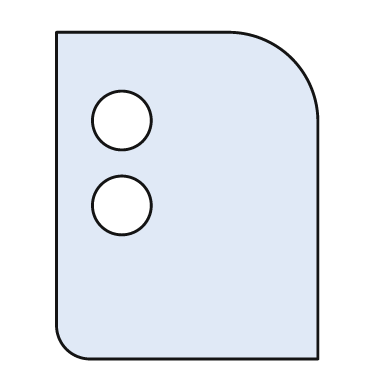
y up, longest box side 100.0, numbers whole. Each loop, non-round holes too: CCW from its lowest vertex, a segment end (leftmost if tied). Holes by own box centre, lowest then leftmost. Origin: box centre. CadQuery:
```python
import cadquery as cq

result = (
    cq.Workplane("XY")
    .moveTo(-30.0, -50.0)
    .lineTo(40.0, -50.0)
    .lineTo(40.0, 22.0)
    .threePointArc((32.0, 42.0), (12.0, 50.0))
    .lineTo(-40.0, 50.0)
    .lineTo(-40.0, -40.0)
    .threePointArc((-37.0, -47.0), (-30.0, -50.0))
    .close()
    .moveTo(-20.0, -3.0)
    .circle(9.0)
    .moveTo(-20.0, 23.0)
    .circle(9.0)
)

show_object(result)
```